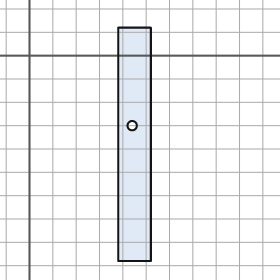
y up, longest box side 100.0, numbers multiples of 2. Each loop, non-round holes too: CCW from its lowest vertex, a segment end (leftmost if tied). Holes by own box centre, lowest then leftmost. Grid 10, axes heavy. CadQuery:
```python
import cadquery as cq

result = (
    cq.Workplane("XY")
    .moveTo(38.0, -88.0)
    .lineTo(52.0, -88.0)
    .lineTo(52.0, 12.0)
    .lineTo(38.0, 12.0)
    .close()
    .moveTo(44.0, -30.0)
    .circle(2.0)
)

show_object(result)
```